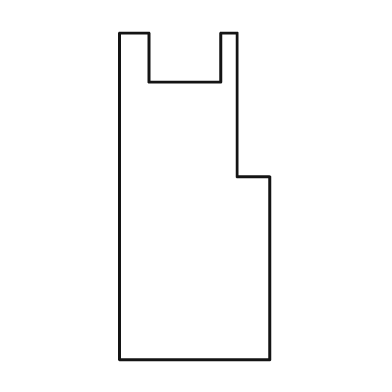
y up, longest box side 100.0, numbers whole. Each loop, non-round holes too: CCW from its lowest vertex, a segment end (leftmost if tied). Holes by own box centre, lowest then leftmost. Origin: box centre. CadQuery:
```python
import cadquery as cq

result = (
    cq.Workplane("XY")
    .moveTo(-23.0, -50.0)
    .lineTo(23.0, -50.0)
    .lineTo(23.0, 6.0)
    .lineTo(13.0, 6.0)
    .lineTo(13.0, 50.0)
    .lineTo(8.0, 50.0)
    .lineTo(8.0, 35.0)
    .lineTo(-14.0, 35.0)
    .lineTo(-14.0, 50.0)
    .lineTo(-23.0, 50.0)
    .close()
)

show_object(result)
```